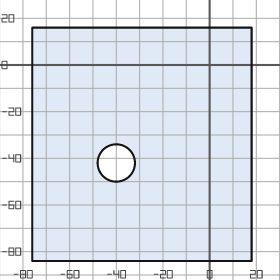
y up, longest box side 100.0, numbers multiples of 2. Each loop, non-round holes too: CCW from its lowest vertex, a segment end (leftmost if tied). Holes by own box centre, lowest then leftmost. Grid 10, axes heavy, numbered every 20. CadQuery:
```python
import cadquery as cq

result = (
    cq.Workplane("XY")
    .moveTo(-76.0, -84.0)
    .lineTo(18.0, -84.0)
    .lineTo(18.0, 16.0)
    .lineTo(-76.0, 16.0)
    .close()
    .moveTo(-40.0, -42.0)
    .circle(8.0)
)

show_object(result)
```